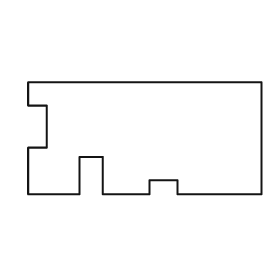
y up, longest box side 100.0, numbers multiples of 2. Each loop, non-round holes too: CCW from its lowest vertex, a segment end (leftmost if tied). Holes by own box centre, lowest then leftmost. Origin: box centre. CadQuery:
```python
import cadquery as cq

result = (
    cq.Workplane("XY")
    .moveTo(-50.0, -24.0)
    .lineTo(-28.0, -24.0)
    .lineTo(-28.0, -8.0)
    .lineTo(-18.0, -8.0)
    .lineTo(-18.0, -24.0)
    .lineTo(2.0, -24.0)
    .lineTo(2.0, -18.0)
    .lineTo(14.0, -18.0)
    .lineTo(14.0, -24.0)
    .lineTo(50.0, -24.0)
    .lineTo(50.0, 24.0)
    .lineTo(-50.0, 24.0)
    .lineTo(-50.0, 14.0)
    .lineTo(-42.0, 14.0)
    .lineTo(-42.0, -4.0)
    .lineTo(-50.0, -4.0)
    .close()
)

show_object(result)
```